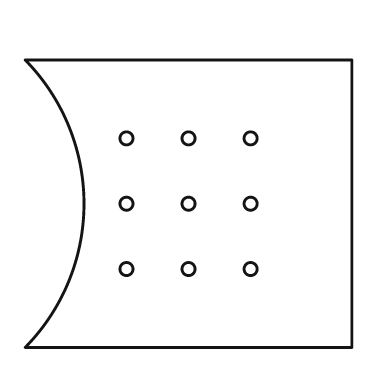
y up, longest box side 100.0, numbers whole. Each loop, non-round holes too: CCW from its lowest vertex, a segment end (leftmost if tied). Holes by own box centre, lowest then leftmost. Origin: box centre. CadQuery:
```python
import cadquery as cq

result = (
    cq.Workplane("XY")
    .moveTo(-50.0, -44.0)
    .lineTo(50.0, -44.0)
    .lineTo(50.0, 44.0)
    .lineTo(-50.0, 44.0)
    .threePointArc((-32.0, 0.0), (-50.0, -44.0))
    .close()
    .moveTo(-19.0, -20.0)
    .circle(2.0)
    .moveTo(0.0, -20.0)
    .circle(2.0)
    .moveTo(19.0, -20.0)
    .circle(2.0)
    .moveTo(-19.0, 0.0)
    .circle(2.0)
    .moveTo(0.0, 0.0)
    .circle(2.0)
    .moveTo(19.0, 0.0)
    .circle(2.0)
    .moveTo(-19.0, 20.0)
    .circle(2.0)
    .moveTo(0.0, 20.0)
    .circle(2.0)
    .moveTo(19.0, 20.0)
    .circle(2.0)
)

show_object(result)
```